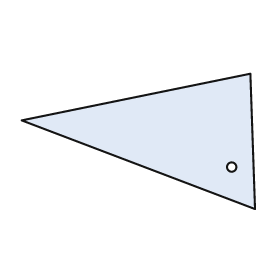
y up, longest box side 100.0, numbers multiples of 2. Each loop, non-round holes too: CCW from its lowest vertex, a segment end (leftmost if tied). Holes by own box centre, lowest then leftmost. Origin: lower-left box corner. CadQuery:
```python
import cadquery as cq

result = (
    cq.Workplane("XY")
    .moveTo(100.0, 0.0)
    .lineTo(98.0, 58.0)
    .lineTo(0.0, 38.0)
    .close()
    .moveTo(90.0, 18.0)
    .circle(2.0)
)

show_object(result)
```